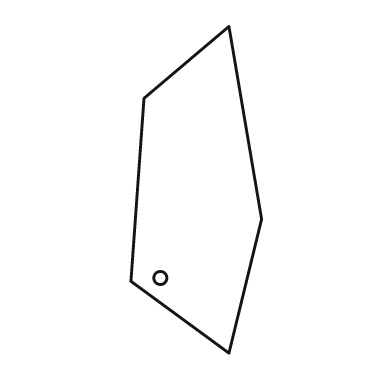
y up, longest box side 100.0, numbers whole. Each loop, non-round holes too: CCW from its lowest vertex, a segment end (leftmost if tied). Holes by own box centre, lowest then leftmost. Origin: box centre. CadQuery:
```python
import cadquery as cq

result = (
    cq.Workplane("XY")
    .moveTo(10.0, -50.0)
    .lineTo(20.0, -9.0)
    .lineTo(10.0, 50.0)
    .lineTo(-16.0, 28.0)
    .lineTo(-20.0, -28.0)
    .close()
    .moveTo(-11.0, -27.0)
    .circle(2.0)
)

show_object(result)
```